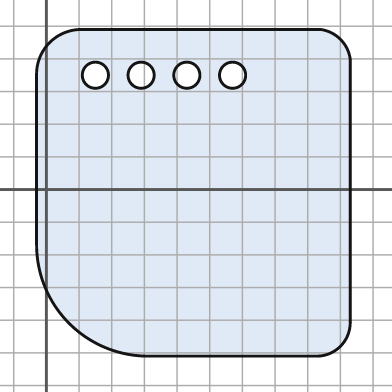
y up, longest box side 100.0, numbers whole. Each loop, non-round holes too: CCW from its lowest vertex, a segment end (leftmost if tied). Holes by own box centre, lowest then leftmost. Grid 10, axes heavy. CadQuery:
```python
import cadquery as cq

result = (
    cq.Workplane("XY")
    .moveTo(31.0, -51.0)
    .lineTo(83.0, -51.0)
    .threePointArc((90.0, -48.0), (93.0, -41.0))
    .lineTo(93.0, 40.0)
    .threePointArc((90.0, 46.0), (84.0, 49.0))
    .lineTo(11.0, 49.0)
    .threePointArc((1.0, 45.0), (-3.0, 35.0))
    .lineTo(-3.0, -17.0)
    .threePointArc((7.0, -41.0), (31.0, -51.0))
    .close()
    .moveTo(15.0, 35.0)
    .circle(4.0)
    .moveTo(29.0, 35.0)
    .circle(4.0)
    .moveTo(43.0, 35.0)
    .circle(4.0)
    .moveTo(57.0, 35.0)
    .circle(4.0)
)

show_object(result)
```